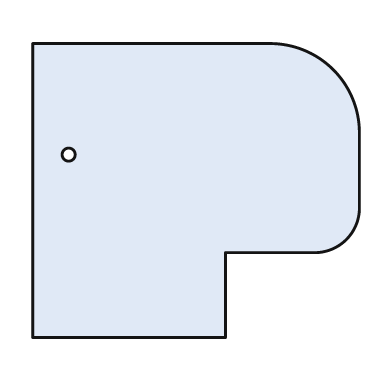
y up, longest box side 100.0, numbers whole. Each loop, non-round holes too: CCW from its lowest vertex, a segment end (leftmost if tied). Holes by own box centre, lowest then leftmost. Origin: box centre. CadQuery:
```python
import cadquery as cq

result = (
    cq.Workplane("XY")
    .moveTo(-50.0, -45.0)
    .lineTo(9.0, -45.0)
    .lineTo(9.0, -19.0)
    .lineTo(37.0, -19.0)
    .threePointArc((46.0, -15.0), (50.0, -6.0))
    .lineTo(50.0, 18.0)
    .threePointArc((42.0, 37.0), (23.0, 45.0))
    .lineTo(-50.0, 45.0)
    .close()
    .moveTo(-39.0, 11.0)
    .circle(2.0)
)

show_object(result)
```